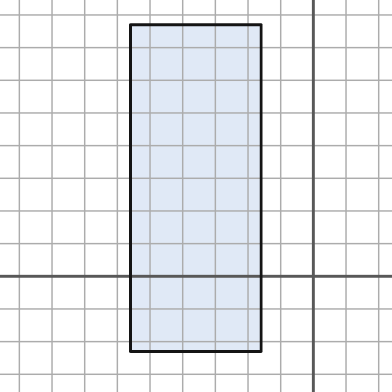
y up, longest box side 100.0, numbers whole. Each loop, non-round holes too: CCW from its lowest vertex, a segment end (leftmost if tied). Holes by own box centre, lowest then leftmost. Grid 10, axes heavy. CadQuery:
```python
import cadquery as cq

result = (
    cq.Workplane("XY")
    .moveTo(-56.0, -23.0)
    .lineTo(-16.0, -23.0)
    .lineTo(-16.0, 77.0)
    .lineTo(-56.0, 77.0)
    .close()
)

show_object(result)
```